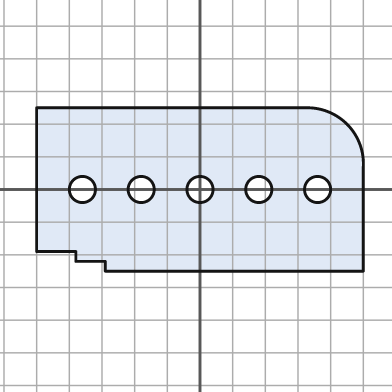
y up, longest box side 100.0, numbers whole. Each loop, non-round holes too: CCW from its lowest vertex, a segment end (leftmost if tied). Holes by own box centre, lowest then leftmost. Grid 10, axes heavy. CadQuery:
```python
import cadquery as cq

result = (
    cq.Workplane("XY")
    .moveTo(-29.0, -25.0)
    .lineTo(50.0, -25.0)
    .lineTo(50.0, 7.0)
    .threePointArc((45.0, 20.0), (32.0, 25.0))
    .lineTo(-50.0, 25.0)
    .lineTo(-50.0, -19.0)
    .lineTo(-38.0, -19.0)
    .lineTo(-38.0, -22.0)
    .lineTo(-29.0, -22.0)
    .close()
    .moveTo(-36.0, 0.0)
    .circle(4.0)
    .moveTo(-18.0, 0.0)
    .circle(4.0)
    .moveTo(0.0, 0.0)
    .circle(4.0)
    .moveTo(18.0, 0.0)
    .circle(4.0)
    .moveTo(36.0, 0.0)
    .circle(4.0)
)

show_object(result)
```